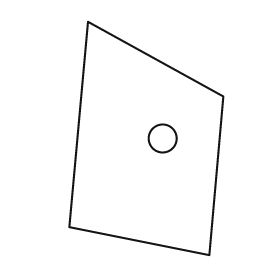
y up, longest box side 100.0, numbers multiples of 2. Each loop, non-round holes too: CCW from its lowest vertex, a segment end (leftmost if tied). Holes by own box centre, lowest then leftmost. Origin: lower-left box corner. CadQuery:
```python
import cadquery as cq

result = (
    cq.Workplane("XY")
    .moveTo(60.0, 0.0)
    .lineTo(66.0, 68.0)
    .lineTo(8.0, 100.0)
    .lineTo(0.0, 12.0)
    .close()
    .moveTo(40.0, 50.0)
    .circle(6.0)
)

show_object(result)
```